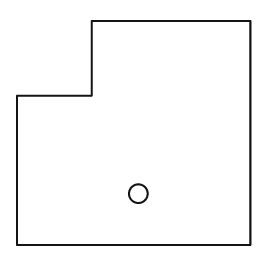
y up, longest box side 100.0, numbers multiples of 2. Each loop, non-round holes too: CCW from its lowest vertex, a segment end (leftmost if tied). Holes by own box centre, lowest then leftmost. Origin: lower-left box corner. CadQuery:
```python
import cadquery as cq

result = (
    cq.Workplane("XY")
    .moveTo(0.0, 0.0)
    .lineTo(100.0, 0.0)
    .lineTo(100.0, 96.0)
    .lineTo(32.0, 96.0)
    .lineTo(32.0, 64.0)
    .lineTo(0.0, 64.0)
    .close()
    .moveTo(52.0, 22.0)
    .circle(4.0)
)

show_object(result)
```